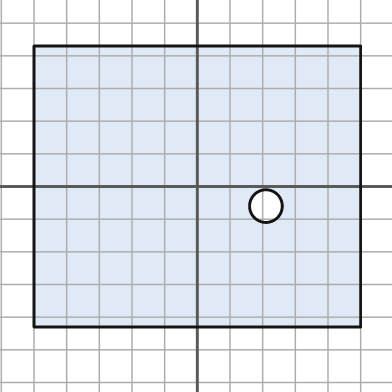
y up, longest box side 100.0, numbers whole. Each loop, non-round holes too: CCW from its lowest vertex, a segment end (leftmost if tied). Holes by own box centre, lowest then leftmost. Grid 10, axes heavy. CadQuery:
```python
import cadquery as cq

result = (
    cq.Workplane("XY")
    .moveTo(-50.0, -43.0)
    .lineTo(50.0, -43.0)
    .lineTo(50.0, 43.0)
    .lineTo(-50.0, 43.0)
    .close()
    .moveTo(21.0, -6.0)
    .circle(5.0)
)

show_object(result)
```